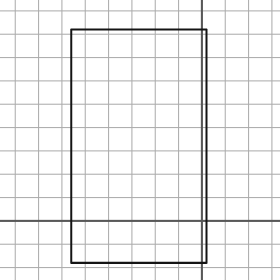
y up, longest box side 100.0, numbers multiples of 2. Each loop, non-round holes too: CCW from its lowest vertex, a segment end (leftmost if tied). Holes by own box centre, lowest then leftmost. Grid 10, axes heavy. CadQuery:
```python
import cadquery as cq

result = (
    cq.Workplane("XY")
    .moveTo(-56.0, -18.0)
    .lineTo(2.0, -18.0)
    .lineTo(2.0, 82.0)
    .lineTo(-56.0, 82.0)
    .close()
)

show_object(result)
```